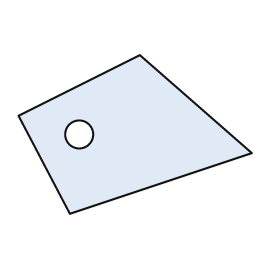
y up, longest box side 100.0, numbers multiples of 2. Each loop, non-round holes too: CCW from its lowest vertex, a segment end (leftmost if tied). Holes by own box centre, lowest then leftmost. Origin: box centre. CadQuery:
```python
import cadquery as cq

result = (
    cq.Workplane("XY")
    .moveTo(-28.0, -34.0)
    .lineTo(50.0, -8.0)
    .lineTo(2.0, 34.0)
    .lineTo(-50.0, 8.0)
    .close()
    .moveTo(-24.0, 0.0)
    .circle(6.0)
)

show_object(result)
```